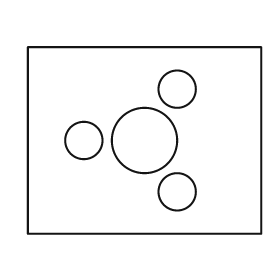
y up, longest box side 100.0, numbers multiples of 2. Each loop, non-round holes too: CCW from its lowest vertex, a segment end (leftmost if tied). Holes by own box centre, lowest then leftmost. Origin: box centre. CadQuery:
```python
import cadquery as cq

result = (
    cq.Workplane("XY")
    .moveTo(-50.0, -40.0)
    .lineTo(50.0, -40.0)
    .lineTo(50.0, 40.0)
    .lineTo(-50.0, 40.0)
    .close()
    .moveTo(14.0, -22.0)
    .circle(8.0)
    .moveTo(-26.0, 0.0)
    .circle(8.0)
    .moveTo(0.0, 0.0)
    .circle(14.0)
    .moveTo(14.0, 22.0)
    .circle(8.0)
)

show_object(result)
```